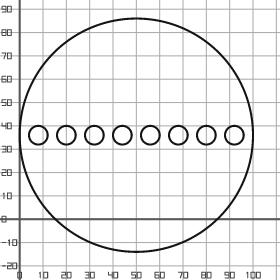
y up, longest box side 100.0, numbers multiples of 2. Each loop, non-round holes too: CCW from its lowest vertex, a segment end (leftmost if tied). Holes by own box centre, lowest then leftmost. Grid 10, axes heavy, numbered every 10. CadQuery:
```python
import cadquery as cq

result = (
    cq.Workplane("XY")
    .moveTo(50.0, 36.0)
    .circle(50.0)
    .moveTo(8.0, 36.0)
    .circle(4.0)
    .moveTo(20.0, 36.0)
    .circle(4.0)
    .moveTo(32.0, 36.0)
    .circle(4.0)
    .moveTo(44.0, 36.0)
    .circle(4.0)
    .moveTo(56.0, 36.0)
    .circle(4.0)
    .moveTo(68.0, 36.0)
    .circle(4.0)
    .moveTo(80.0, 36.0)
    .circle(4.0)
    .moveTo(92.0, 36.0)
    .circle(4.0)
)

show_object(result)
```